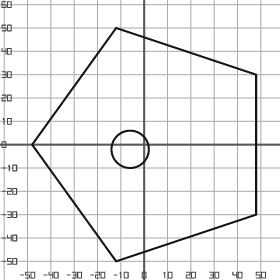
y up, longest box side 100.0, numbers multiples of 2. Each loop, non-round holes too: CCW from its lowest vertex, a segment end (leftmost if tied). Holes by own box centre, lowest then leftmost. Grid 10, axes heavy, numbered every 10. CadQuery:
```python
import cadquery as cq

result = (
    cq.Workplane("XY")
    .moveTo(-12.0, -50.0)
    .lineTo(48.0, -30.0)
    .lineTo(48.0, 30.0)
    .lineTo(-12.0, 50.0)
    .lineTo(-48.0, 0.0)
    .close()
    .moveTo(-6.0, -2.0)
    .circle(8.0)
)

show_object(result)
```